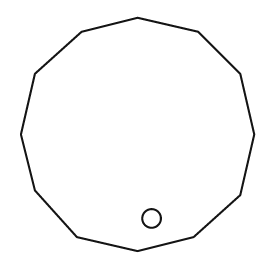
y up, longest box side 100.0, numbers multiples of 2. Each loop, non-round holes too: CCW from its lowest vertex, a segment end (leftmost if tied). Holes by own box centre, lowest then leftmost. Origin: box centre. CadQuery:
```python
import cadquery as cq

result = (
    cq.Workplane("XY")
    .moveTo(0.0, -50.0)
    .lineTo(24.0, -44.0)
    .lineTo(44.0, -26.0)
    .lineTo(50.0, 0.0)
    .lineTo(44.0, 26.0)
    .lineTo(26.0, 44.0)
    .lineTo(0.0, 50.0)
    .lineTo(-24.0, 44.0)
    .lineTo(-44.0, 26.0)
    .lineTo(-50.0, 0.0)
    .lineTo(-44.0, -24.0)
    .lineTo(-26.0, -44.0)
    .close()
    .moveTo(6.0, -36.0)
    .circle(4.0)
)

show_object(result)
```